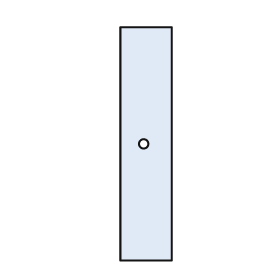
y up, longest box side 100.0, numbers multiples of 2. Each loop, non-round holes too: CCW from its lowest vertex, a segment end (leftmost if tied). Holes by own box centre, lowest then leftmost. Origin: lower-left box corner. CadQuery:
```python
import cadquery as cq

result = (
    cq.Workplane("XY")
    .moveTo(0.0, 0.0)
    .lineTo(22.0, 0.0)
    .lineTo(22.0, 100.0)
    .lineTo(0.0, 100.0)
    .close()
    .moveTo(10.0, 50.0)
    .circle(2.0)
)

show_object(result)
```